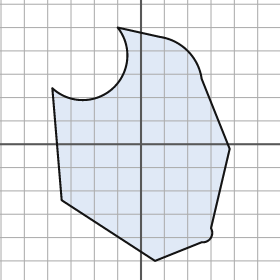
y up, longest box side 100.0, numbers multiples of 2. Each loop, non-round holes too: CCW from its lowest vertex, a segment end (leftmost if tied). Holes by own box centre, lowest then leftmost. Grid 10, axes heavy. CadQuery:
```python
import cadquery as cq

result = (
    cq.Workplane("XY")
    .moveTo(6.0, -50.0)
    .lineTo(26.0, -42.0)
    .threePointArc((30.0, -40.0), (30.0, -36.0))
    .lineTo(38.0, -2.0)
    .lineTo(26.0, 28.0)
    .threePointArc((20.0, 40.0), (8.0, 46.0))
    .lineTo(-10.0, 50.0)
    .threePointArc((-12.0, 24.0), (-38.0, 24.0))
    .lineTo(-34.0, -24.0)
    .close()
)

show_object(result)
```